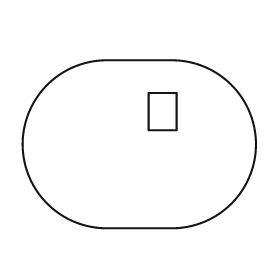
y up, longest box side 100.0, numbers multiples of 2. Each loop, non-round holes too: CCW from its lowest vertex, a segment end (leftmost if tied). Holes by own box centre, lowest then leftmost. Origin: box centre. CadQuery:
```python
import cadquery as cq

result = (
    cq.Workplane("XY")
    .moveTo(-14.0, -36.0)
    .lineTo(14.0, -36.0)
    .threePointArc((50.0, 0.0), (14.0, 36.0))
    .lineTo(-14.0, 36.0)
    .threePointArc((-50.0, 0.0), (-14.0, -36.0))
    .close()
    .moveTo(4.0, 6.0)
    .lineTo(16.0, 6.0)
    .lineTo(16.0, 22.0)
    .lineTo(4.0, 22.0)
    .close()
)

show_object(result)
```